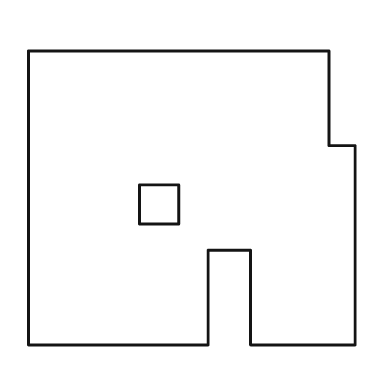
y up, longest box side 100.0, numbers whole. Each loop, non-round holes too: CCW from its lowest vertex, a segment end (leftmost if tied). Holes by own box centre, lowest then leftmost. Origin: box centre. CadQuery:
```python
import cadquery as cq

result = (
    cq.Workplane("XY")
    .moveTo(-50.0, -45.0)
    .lineTo(5.0, -45.0)
    .lineTo(5.0, -16.0)
    .lineTo(18.0, -16.0)
    .lineTo(18.0, -45.0)
    .lineTo(50.0, -45.0)
    .lineTo(50.0, 16.0)
    .lineTo(42.0, 16.0)
    .lineTo(42.0, 45.0)
    .lineTo(-50.0, 45.0)
    .close()
    .moveTo(-16.0, -8.0)
    .lineTo(-4.0, -8.0)
    .lineTo(-4.0, 4.0)
    .lineTo(-16.0, 4.0)
    .close()
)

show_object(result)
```